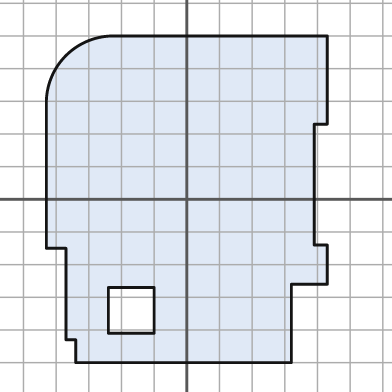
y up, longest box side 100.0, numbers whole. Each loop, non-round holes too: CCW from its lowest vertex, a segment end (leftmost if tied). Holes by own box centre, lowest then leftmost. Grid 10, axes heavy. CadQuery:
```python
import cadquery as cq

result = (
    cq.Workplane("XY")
    .moveTo(-34.0, -50.0)
    .lineTo(32.0, -50.0)
    .lineTo(32.0, -26.0)
    .lineTo(43.0, -26.0)
    .lineTo(43.0, -14.0)
    .lineTo(39.0, -14.0)
    .lineTo(39.0, 23.0)
    .lineTo(43.0, 23.0)
    .lineTo(43.0, 50.0)
    .lineTo(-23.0, 50.0)
    .threePointArc((-37.0, 44.0), (-43.0, 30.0))
    .lineTo(-43.0, -15.0)
    .lineTo(-37.0, -15.0)
    .lineTo(-37.0, -43.0)
    .lineTo(-34.0, -43.0)
    .close()
    .moveTo(-24.0, -41.0)
    .lineTo(-10.0, -41.0)
    .lineTo(-10.0, -27.0)
    .lineTo(-24.0, -27.0)
    .close()
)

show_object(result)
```